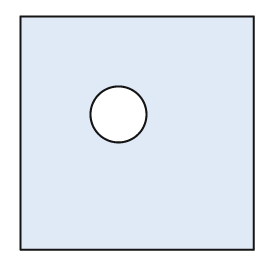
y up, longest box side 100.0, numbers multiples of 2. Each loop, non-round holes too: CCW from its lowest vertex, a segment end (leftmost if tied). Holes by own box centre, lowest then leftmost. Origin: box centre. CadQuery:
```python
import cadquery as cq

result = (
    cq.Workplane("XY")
    .moveTo(-50.0, -50.0)
    .lineTo(50.0, -50.0)
    .lineTo(50.0, 50.0)
    .lineTo(-50.0, 50.0)
    .close()
    .moveTo(-8.0, 8.0)
    .circle(12.0)
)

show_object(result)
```